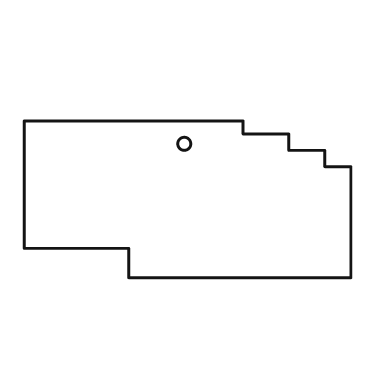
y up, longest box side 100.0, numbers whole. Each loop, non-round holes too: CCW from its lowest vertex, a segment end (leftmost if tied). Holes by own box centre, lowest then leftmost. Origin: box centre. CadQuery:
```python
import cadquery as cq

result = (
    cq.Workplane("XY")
    .moveTo(-18.0, -24.0)
    .lineTo(50.0, -24.0)
    .lineTo(50.0, 10.0)
    .lineTo(42.0, 10.0)
    .lineTo(42.0, 15.0)
    .lineTo(31.0, 15.0)
    .lineTo(31.0, 20.0)
    .lineTo(17.0, 20.0)
    .lineTo(17.0, 24.0)
    .lineTo(-50.0, 24.0)
    .lineTo(-50.0, -15.0)
    .lineTo(-18.0, -15.0)
    .close()
    .moveTo(-1.0, 17.0)
    .circle(2.0)
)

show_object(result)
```